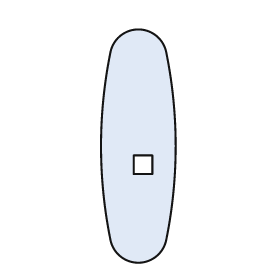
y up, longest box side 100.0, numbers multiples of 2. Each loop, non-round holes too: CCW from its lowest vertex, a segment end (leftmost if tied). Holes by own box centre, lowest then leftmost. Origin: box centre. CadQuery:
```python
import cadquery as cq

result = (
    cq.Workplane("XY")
    .moveTo(-12.0, -40.0)
    .threePointArc((0.0, -50.0), (12.0, -40.0))
    .threePointArc((16.0, 0.0), (12.0, 40.0))
    .threePointArc((0.0, 50.0), (-12.0, 40.0))
    .threePointArc((-16.0, 0.0), (-12.0, -40.0))
    .close()
    .moveTo(-2.0, -12.0)
    .lineTo(6.0, -12.0)
    .lineTo(6.0, -4.0)
    .lineTo(-2.0, -4.0)
    .close()
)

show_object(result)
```